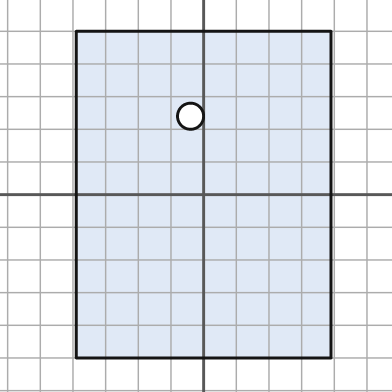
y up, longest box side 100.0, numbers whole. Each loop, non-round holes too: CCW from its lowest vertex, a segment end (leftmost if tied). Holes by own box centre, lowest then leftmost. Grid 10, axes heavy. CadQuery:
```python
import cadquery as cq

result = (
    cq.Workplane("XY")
    .moveTo(-39.0, -50.0)
    .lineTo(39.0, -50.0)
    .lineTo(39.0, 50.0)
    .lineTo(-39.0, 50.0)
    .close()
    .moveTo(-4.0, 24.0)
    .circle(4.0)
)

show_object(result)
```